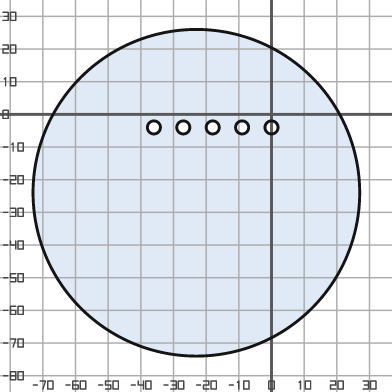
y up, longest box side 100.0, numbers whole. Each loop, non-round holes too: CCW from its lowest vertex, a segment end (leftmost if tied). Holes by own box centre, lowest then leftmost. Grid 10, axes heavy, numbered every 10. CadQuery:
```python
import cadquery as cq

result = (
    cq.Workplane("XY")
    .moveTo(-23.0, -24.0)
    .circle(50.0)
    .moveTo(-36.0, -4.0)
    .circle(2.0)
    .moveTo(-27.0, -4.0)
    .circle(2.0)
    .moveTo(-18.0, -4.0)
    .circle(2.0)
    .moveTo(-9.0, -4.0)
    .circle(2.0)
    .moveTo(0.0, -4.0)
    .circle(2.0)
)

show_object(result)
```